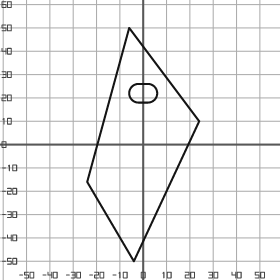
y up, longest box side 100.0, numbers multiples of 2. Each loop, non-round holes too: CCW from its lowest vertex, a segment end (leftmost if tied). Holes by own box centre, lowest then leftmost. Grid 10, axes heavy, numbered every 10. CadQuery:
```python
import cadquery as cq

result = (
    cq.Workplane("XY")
    .moveTo(-4.0, -50.0)
    .lineTo(24.0, 10.0)
    .lineTo(-6.0, 50.0)
    .lineTo(-24.0, -16.0)
    .close()
    .moveTo(-2.0, 18.0)
    .lineTo(2.0, 18.0)
    .threePointArc((6.0, 22.0), (2.0, 26.0))
    .lineTo(-2.0, 26.0)
    .threePointArc((-6.0, 22.0), (-2.0, 18.0))
    .close()
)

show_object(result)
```